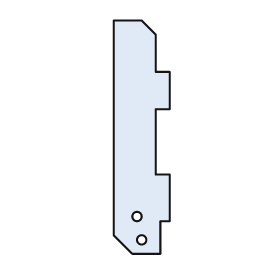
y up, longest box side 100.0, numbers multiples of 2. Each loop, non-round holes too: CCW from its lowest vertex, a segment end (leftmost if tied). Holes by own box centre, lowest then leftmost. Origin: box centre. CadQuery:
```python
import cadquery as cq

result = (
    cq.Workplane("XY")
    .moveTo(-4.0, -50.0)
    .lineTo(8.0, -50.0)
    .lineTo(8.0, -36.0)
    .lineTo(12.0, -36.0)
    .lineTo(12.0, -16.0)
    .lineTo(6.0, -16.0)
    .lineTo(6.0, 12.0)
    .lineTo(12.0, 12.0)
    .lineTo(12.0, 28.0)
    .lineTo(6.0, 28.0)
    .lineTo(6.0, 44.0)
    .lineTo(0.0, 50.0)
    .lineTo(-12.0, 50.0)
    .lineTo(-12.0, -42.0)
    .close()
    .moveTo(0.0, -44.0)
    .circle(2.0)
    .moveTo(-2.0, -34.0)
    .circle(2.0)
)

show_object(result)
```